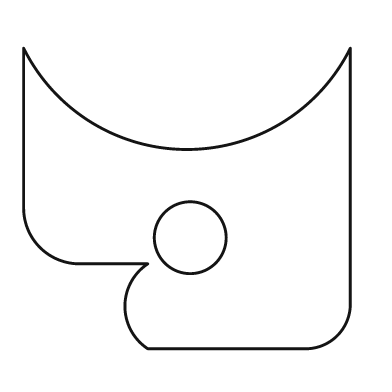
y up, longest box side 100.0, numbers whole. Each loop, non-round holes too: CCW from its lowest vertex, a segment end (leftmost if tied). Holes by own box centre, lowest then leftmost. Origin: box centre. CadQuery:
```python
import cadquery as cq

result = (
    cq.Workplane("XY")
    .moveTo(-12.0, -46.0)
    .lineTo(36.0, -46.0)
    .threePointArc((46.0, -42.0), (50.0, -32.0))
    .lineTo(50.0, 46.0)
    .threePointArc((0.0, 15.0), (-50.0, 46.0))
    .lineTo(-50.0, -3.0)
    .threePointArc((-45.0, -15.0), (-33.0, -20.0))
    .lineTo(-12.0, -20.0)
    .threePointArc((-19.0, -33.0), (-12.0, -46.0))
    .close()
    .moveTo(1.0, -12.0)
    .circle(11.0)
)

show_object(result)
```